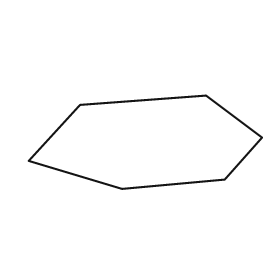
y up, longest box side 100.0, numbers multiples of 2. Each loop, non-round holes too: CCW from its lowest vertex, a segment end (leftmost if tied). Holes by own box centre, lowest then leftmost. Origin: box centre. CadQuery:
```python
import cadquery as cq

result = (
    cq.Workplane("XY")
    .moveTo(-10.0, -20.0)
    .lineTo(34.0, -16.0)
    .lineTo(50.0, 2.0)
    .lineTo(26.0, 20.0)
    .lineTo(-28.0, 16.0)
    .lineTo(-50.0, -8.0)
    .close()
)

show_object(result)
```